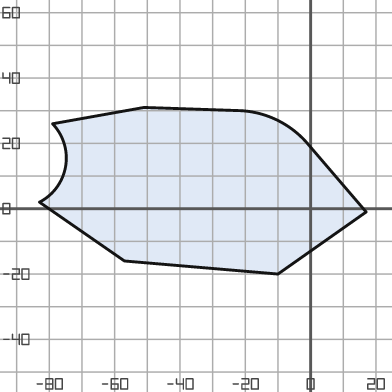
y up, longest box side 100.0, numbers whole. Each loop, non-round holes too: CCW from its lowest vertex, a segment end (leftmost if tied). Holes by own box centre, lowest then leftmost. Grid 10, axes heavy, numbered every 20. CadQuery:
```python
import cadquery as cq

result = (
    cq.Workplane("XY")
    .moveTo(-10.0, -20.0)
    .lineTo(17.0, -1.0)
    .lineTo(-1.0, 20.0)
    .threePointArc((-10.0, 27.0), (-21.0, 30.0))
    .lineTo(-51.0, 31.0)
    .lineTo(-79.0, 26.0)
    .threePointArc((-75.0, 13.0), (-83.0, 2.0))
    .lineTo(-57.0, -16.0)
    .close()
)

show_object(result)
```